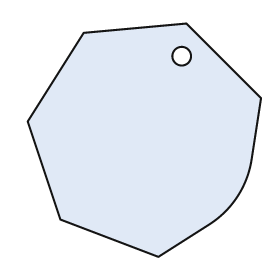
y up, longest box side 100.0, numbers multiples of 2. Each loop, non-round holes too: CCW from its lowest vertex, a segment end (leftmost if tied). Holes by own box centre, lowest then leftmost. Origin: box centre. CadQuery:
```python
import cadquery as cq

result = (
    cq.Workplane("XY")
    .moveTo(6.0, -50.0)
    .lineTo(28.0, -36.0)
    .threePointArc((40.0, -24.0), (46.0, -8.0))
    .lineTo(50.0, 18.0)
    .lineTo(18.0, 50.0)
    .lineTo(-26.0, 46.0)
    .lineTo(-50.0, 8.0)
    .lineTo(-36.0, -34.0)
    .close()
    .moveTo(16.0, 36.0)
    .circle(4.0)
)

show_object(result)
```